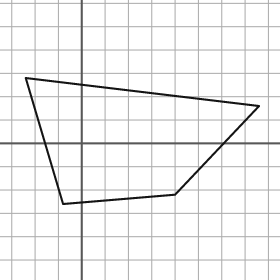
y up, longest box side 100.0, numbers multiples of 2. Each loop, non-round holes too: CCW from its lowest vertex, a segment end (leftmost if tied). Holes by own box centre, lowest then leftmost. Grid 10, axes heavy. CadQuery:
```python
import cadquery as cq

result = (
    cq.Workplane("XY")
    .moveTo(-8.0, -26.0)
    .lineTo(40.0, -22.0)
    .lineTo(76.0, 16.0)
    .lineTo(-24.0, 28.0)
    .close()
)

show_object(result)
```